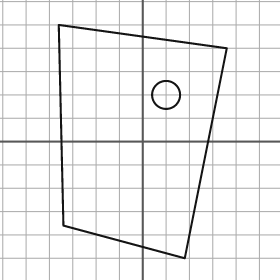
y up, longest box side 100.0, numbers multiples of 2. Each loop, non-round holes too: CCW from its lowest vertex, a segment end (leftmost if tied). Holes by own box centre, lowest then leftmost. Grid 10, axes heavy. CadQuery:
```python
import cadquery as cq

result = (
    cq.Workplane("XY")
    .moveTo(18.0, -50.0)
    .lineTo(36.0, 40.0)
    .lineTo(-36.0, 50.0)
    .lineTo(-34.0, -36.0)
    .close()
    .moveTo(10.0, 20.0)
    .circle(6.0)
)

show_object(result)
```